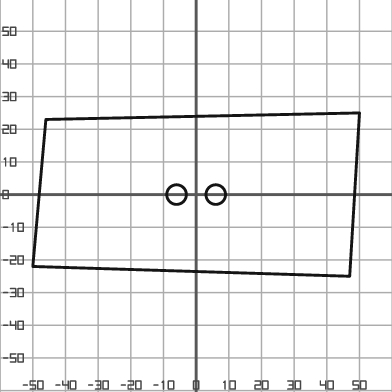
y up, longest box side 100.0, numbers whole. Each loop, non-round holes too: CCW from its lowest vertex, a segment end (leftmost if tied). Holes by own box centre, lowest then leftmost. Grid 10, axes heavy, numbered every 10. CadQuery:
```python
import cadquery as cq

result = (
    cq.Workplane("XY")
    .moveTo(47.0, -25.0)
    .lineTo(50.0, 25.0)
    .lineTo(-46.0, 23.0)
    .lineTo(-50.0, -22.0)
    .close()
    .moveTo(-6.0, 0.0)
    .circle(3.0)
    .moveTo(6.0, 0.0)
    .circle(3.0)
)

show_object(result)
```